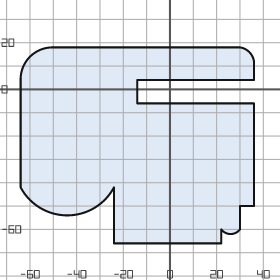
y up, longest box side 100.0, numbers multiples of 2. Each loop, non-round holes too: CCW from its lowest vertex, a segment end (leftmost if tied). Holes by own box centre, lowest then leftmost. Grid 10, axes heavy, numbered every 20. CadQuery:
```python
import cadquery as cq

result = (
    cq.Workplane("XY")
    .moveTo(-24.0, -66.0)
    .lineTo(22.0, -66.0)
    .lineTo(22.0, -60.0)
    .threePointArc((26.0, -62.0), (30.0, -60.0))
    .lineTo(30.0, -50.0)
    .lineTo(36.0, -50.0)
    .lineTo(36.0, -6.0)
    .lineTo(-14.0, -6.0)
    .lineTo(-14.0, 4.0)
    .lineTo(36.0, 4.0)
    .lineTo(36.0, 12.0)
    .threePointArc((34.0, 16.0), (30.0, 18.0))
    .lineTo(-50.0, 18.0)
    .threePointArc((-60.0, 14.0), (-64.0, 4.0))
    .lineTo(-64.0, -42.0)
    .threePointArc((-44.0, -54.0), (-24.0, -42.0))
    .close()
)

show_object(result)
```